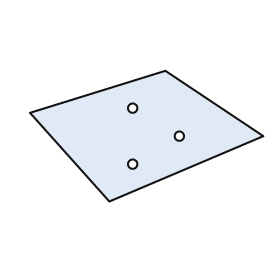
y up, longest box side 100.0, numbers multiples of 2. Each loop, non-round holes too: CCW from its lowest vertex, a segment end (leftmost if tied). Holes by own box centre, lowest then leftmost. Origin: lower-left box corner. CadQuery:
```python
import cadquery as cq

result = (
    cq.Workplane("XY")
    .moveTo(34.0, 0.0)
    .lineTo(100.0, 28.0)
    .lineTo(58.0, 56.0)
    .lineTo(0.0, 38.0)
    .close()
    .moveTo(44.0, 16.0)
    .circle(2.0)
    .moveTo(64.0, 28.0)
    .circle(2.0)
    .moveTo(44.0, 40.0)
    .circle(2.0)
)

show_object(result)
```